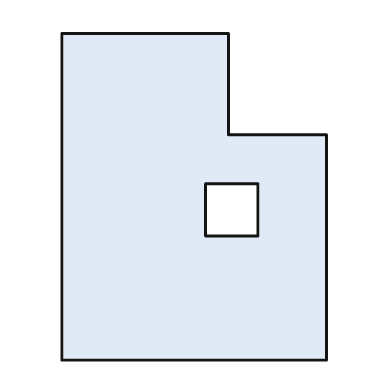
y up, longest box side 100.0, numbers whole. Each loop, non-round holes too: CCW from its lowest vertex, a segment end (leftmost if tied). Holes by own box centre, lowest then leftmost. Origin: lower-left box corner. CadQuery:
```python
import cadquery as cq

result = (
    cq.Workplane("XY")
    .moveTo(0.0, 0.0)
    .lineTo(81.0, 0.0)
    .lineTo(81.0, 69.0)
    .lineTo(51.0, 69.0)
    .lineTo(51.0, 100.0)
    .lineTo(0.0, 100.0)
    .close()
    .moveTo(44.0, 38.0)
    .lineTo(60.0, 38.0)
    .lineTo(60.0, 54.0)
    .lineTo(44.0, 54.0)
    .close()
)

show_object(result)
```